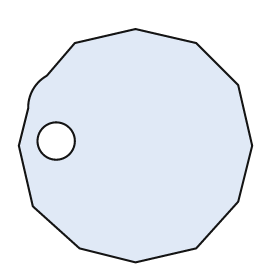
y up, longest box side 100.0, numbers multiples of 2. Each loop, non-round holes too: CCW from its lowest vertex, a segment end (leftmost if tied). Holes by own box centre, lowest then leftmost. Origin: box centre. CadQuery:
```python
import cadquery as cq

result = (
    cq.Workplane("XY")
    .moveTo(0.0, -50.0)
    .lineTo(26.0, -44.0)
    .lineTo(44.0, -24.0)
    .lineTo(50.0, 0.0)
    .lineTo(44.0, 26.0)
    .lineTo(26.0, 44.0)
    .lineTo(0.0, 50.0)
    .lineTo(-26.0, 44.0)
    .lineTo(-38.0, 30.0)
    .threePointArc((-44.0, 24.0), (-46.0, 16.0))
    .lineTo(-50.0, 0.0)
    .lineTo(-44.0, -26.0)
    .lineTo(-24.0, -44.0)
    .close()
    .moveTo(-34.0, 2.0)
    .circle(8.0)
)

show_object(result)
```